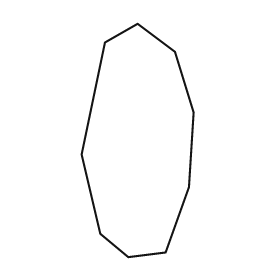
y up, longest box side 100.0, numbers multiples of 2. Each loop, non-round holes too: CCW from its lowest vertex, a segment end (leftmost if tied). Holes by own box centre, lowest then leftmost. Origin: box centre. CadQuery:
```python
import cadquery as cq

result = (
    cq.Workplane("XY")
    .moveTo(-4.0, -50.0)
    .lineTo(12.0, -48.0)
    .lineTo(22.0, -20.0)
    .lineTo(24.0, 12.0)
    .lineTo(16.0, 38.0)
    .lineTo(0.0, 50.0)
    .lineTo(-14.0, 42.0)
    .lineTo(-24.0, -6.0)
    .lineTo(-16.0, -40.0)
    .close()
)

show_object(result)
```